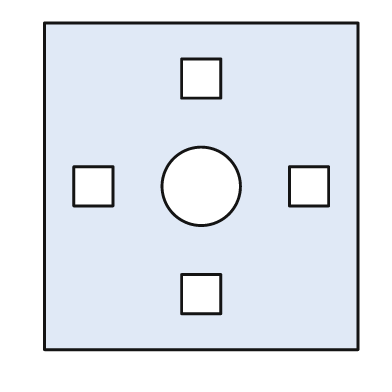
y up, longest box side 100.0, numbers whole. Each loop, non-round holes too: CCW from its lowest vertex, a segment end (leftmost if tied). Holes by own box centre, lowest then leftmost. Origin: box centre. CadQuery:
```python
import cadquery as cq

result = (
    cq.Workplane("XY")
    .moveTo(-48.0, -50.0)
    .lineTo(48.0, -50.0)
    .lineTo(48.0, 50.0)
    .lineTo(-48.0, 50.0)
    .close()
    .moveTo(-6.0, -39.0)
    .lineTo(6.0, -39.0)
    .lineTo(6.0, -27.0)
    .lineTo(-6.0, -27.0)
    .close()
    .moveTo(-39.0, -6.0)
    .lineTo(-27.0, -6.0)
    .lineTo(-27.0, 6.0)
    .lineTo(-39.0, 6.0)
    .close()
    .moveTo(0.0, 0.0)
    .circle(12.0)
    .moveTo(27.0, -6.0)
    .lineTo(39.0, -6.0)
    .lineTo(39.0, 6.0)
    .lineTo(27.0, 6.0)
    .close()
    .moveTo(-6.0, 27.0)
    .lineTo(6.0, 27.0)
    .lineTo(6.0, 39.0)
    .lineTo(-6.0, 39.0)
    .close()
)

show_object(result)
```